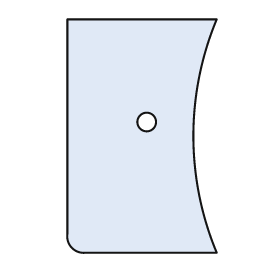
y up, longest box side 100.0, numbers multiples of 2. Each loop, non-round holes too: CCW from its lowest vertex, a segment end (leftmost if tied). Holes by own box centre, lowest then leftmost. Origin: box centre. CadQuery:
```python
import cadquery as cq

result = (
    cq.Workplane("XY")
    .moveTo(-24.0, -50.0)
    .lineTo(32.0, -50.0)
    .threePointArc((22.0, 0.0), (32.0, 50.0))
    .lineTo(-32.0, 50.0)
    .lineTo(-32.0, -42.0)
    .threePointArc((-30.0, -48.0), (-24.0, -50.0))
    .close()
    .moveTo(2.0, 6.0)
    .circle(4.0)
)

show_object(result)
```